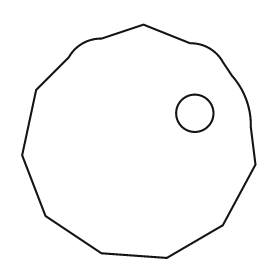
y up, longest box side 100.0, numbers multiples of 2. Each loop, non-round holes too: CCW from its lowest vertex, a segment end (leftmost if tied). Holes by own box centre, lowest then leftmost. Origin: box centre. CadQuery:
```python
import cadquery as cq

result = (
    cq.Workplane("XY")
    .moveTo(12.0, -50.0)
    .lineTo(36.0, -36.0)
    .lineTo(50.0, -10.0)
    .lineTo(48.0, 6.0)
    .threePointArc((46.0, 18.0), (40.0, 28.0))
    .lineTo(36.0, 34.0)
    .threePointArc((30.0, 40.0), (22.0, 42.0))
    .lineTo(2.0, 50.0)
    .lineTo(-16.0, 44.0)
    .threePointArc((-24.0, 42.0), (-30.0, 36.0))
    .lineTo(-44.0, 22.0)
    .lineTo(-50.0, -6.0)
    .lineTo(-40.0, -32.0)
    .lineTo(-16.0, -48.0)
    .close()
    .moveTo(24.0, 12.0)
    .circle(8.0)
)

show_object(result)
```